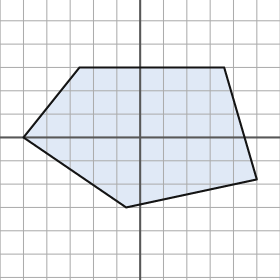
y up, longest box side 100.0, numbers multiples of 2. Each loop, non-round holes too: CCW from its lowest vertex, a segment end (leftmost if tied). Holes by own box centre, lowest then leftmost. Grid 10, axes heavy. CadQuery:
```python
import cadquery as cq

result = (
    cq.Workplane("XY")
    .moveTo(-6.0, -30.0)
    .lineTo(50.0, -18.0)
    .lineTo(36.0, 30.0)
    .lineTo(-26.0, 30.0)
    .lineTo(-50.0, 0.0)
    .close()
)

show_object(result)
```